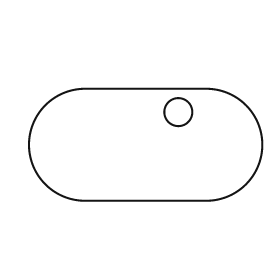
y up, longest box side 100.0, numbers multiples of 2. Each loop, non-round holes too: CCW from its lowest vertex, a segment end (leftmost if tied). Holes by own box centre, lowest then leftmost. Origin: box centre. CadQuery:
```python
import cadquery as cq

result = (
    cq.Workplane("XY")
    .moveTo(-26.0, -24.0)
    .lineTo(26.0, -24.0)
    .threePointArc((50.0, 0.0), (26.0, 24.0))
    .lineTo(-26.0, 24.0)
    .threePointArc((-50.0, 0.0), (-26.0, -24.0))
    .close()
    .moveTo(14.0, 14.0)
    .circle(6.0)
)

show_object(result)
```